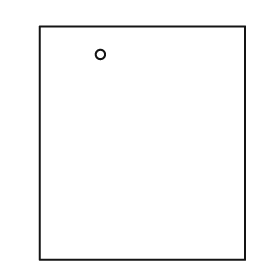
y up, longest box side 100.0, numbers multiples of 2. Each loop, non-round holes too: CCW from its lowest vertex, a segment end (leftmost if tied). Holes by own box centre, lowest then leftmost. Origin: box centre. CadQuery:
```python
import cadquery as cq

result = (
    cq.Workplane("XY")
    .moveTo(-44.0, -50.0)
    .lineTo(44.0, -50.0)
    .lineTo(44.0, 50.0)
    .lineTo(-44.0, 50.0)
    .close()
    .moveTo(-18.0, 38.0)
    .circle(2.0)
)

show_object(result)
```